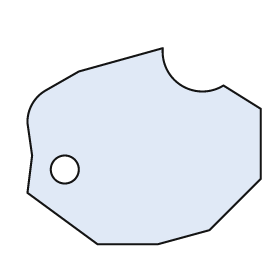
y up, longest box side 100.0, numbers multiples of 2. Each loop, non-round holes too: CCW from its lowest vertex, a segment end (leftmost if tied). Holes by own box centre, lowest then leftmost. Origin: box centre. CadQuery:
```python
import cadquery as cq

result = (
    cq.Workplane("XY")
    .moveTo(-20.0, -42.0)
    .lineTo(6.0, -42.0)
    .lineTo(28.0, -36.0)
    .lineTo(50.0, -14.0)
    .lineTo(50.0, 16.0)
    .lineTo(34.0, 26.0)
    .threePointArc((16.0, 26.0), (8.0, 42.0))
    .lineTo(-28.0, 32.0)
    .lineTo(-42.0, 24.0)
    .threePointArc((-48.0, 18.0), (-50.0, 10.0))
    .lineTo(-48.0, -4.0)
    .lineTo(-50.0, -20.0)
    .close()
    .moveTo(-34.0, -10.0)
    .circle(6.0)
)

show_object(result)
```